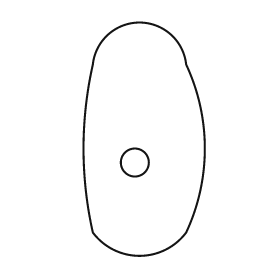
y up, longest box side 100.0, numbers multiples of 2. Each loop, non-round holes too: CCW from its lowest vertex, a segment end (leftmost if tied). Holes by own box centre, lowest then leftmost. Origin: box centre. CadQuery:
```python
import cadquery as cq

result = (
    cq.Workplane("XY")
    .moveTo(-22.0, -40.0)
    .threePointArc((-2.0, -50.0), (18.0, -40.0))
    .threePointArc((26.0, -4.0), (18.0, 32.0))
    .threePointArc((-2.0, 50.0), (-22.0, 32.0))
    .threePointArc((-26.0, -4.0), (-22.0, -40.0))
    .close()
    .moveTo(-4.0, -10.0)
    .circle(6.0)
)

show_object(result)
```